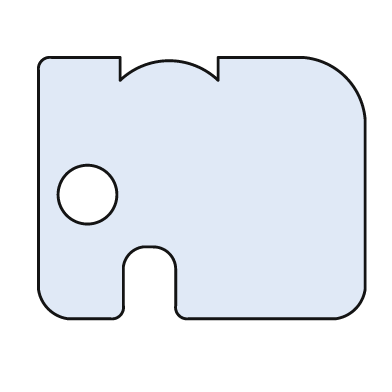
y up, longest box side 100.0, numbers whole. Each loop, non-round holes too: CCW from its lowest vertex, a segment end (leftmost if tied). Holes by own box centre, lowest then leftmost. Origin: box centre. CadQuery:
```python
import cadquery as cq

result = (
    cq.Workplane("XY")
    .moveTo(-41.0, -40.0)
    .lineTo(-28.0, -40.0)
    .threePointArc((-25.0, -39.0), (-24.0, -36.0))
    .lineTo(-24.0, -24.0)
    .threePointArc((-22.0, -20.0), (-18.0, -18.0))
    .lineTo(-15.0, -18.0)
    .threePointArc((-10.0, -20.0), (-8.0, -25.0))
    .lineTo(-8.0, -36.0)
    .threePointArc((-7.0, -39.0), (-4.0, -40.0))
    .lineTo(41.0, -40.0)
    .threePointArc((47.0, -37.0), (50.0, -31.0))
    .lineTo(50.0, 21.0)
    .threePointArc((44.0, 34.0), (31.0, 40.0))
    .lineTo(5.0, 40.0)
    .lineTo(5.0, 33.0)
    .threePointArc((-10.0, 39.0), (-25.0, 33.0))
    .lineTo(-25.0, 40.0)
    .lineTo(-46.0, 40.0)
    .threePointArc((-49.0, 39.0), (-50.0, 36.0))
    .lineTo(-50.0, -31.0)
    .threePointArc((-47.0, -37.0), (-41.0, -40.0))
    .close()
    .moveTo(-35.0, -2.0)
    .circle(9.0)
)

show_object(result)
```